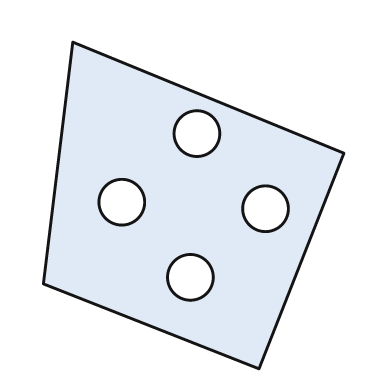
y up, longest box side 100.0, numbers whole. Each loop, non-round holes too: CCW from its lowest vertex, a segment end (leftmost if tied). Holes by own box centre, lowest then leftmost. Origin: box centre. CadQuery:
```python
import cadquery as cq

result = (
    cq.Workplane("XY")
    .moveTo(20.0, -50.0)
    .lineTo(46.0, 16.0)
    .lineTo(-37.0, 50.0)
    .lineTo(-46.0, -24.0)
    .close()
    .moveTo(-1.0, -22.0)
    .circle(7.0)
    .moveTo(22.0, -1.0)
    .circle(7.0)
    .moveTo(-22.0, 1.0)
    .circle(7.0)
    .moveTo(1.0, 22.0)
    .circle(7.0)
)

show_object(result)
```